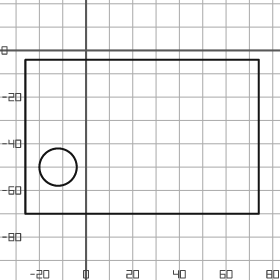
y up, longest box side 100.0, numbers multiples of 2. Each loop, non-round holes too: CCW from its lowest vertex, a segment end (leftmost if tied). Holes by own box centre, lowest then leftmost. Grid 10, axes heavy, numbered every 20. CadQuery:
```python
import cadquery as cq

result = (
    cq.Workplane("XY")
    .moveTo(-26.0, -70.0)
    .lineTo(74.0, -70.0)
    .lineTo(74.0, -4.0)
    .lineTo(-26.0, -4.0)
    .close()
    .moveTo(-12.0, -50.0)
    .circle(8.0)
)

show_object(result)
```